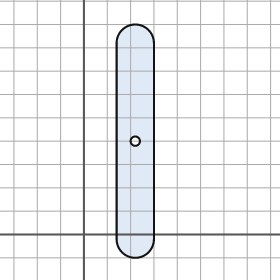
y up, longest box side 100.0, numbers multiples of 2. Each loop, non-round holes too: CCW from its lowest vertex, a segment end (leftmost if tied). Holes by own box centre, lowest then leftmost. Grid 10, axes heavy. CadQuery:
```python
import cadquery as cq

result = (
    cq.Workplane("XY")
    .moveTo(14.0, -2.0)
    .threePointArc((22.0, -10.0), (30.0, -2.0))
    .lineTo(30.0, 82.0)
    .threePointArc((22.0, 90.0), (14.0, 82.0))
    .close()
    .moveTo(22.0, 40.0)
    .circle(2.0)
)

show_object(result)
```